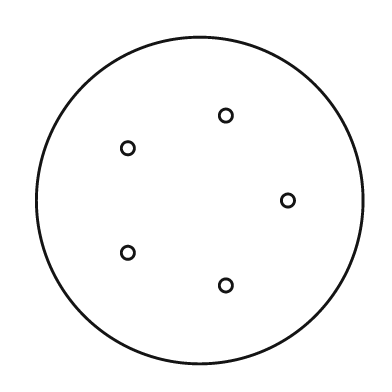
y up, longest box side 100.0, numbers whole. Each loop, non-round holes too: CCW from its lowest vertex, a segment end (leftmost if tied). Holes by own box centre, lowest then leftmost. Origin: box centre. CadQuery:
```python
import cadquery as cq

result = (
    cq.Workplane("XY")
    .moveTo(0.0, 0.0)
    .circle(50.0)
    .moveTo(8.0, -26.0)
    .circle(2.0)
    .moveTo(-22.0, -16.0)
    .circle(2.0)
    .moveTo(27.0, 0.0)
    .circle(2.0)
    .moveTo(-22.0, 16.0)
    .circle(2.0)
    .moveTo(8.0, 26.0)
    .circle(2.0)
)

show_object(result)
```